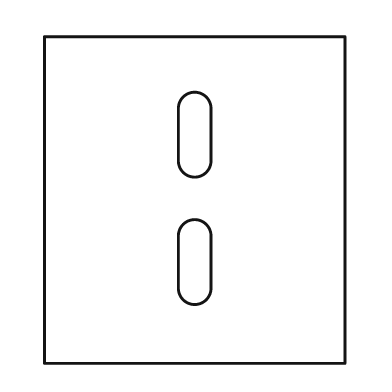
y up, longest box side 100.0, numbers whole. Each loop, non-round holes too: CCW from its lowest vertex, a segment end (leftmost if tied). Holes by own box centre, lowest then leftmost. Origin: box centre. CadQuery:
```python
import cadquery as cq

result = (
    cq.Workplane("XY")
    .moveTo(-46.0, -50.0)
    .lineTo(46.0, -50.0)
    .lineTo(46.0, 50.0)
    .lineTo(-46.0, 50.0)
    .close()
    .moveTo(-5.0, -27.0)
    .threePointArc((0.0, -32.0), (5.0, -27.0))
    .lineTo(5.0, -11.0)
    .threePointArc((0.0, -6.0), (-5.0, -11.0))
    .close()
    .moveTo(-5.0, 12.0)
    .threePointArc((0.0, 7.0), (5.0, 12.0))
    .lineTo(5.0, 28.0)
    .threePointArc((0.0, 33.0), (-5.0, 28.0))
    .close()
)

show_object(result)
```